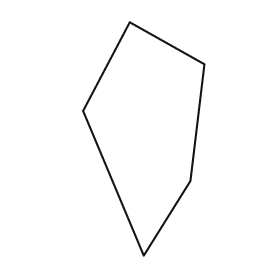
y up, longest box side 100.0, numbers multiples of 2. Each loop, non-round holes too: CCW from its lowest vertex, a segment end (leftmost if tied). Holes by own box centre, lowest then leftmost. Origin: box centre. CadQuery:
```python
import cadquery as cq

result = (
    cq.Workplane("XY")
    .moveTo(0.0, -50.0)
    .lineTo(20.0, -18.0)
    .lineTo(26.0, 32.0)
    .lineTo(-6.0, 50.0)
    .lineTo(-26.0, 12.0)
    .close()
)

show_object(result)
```